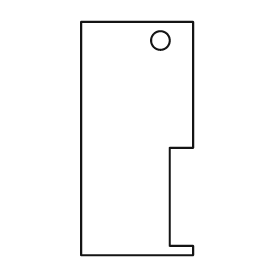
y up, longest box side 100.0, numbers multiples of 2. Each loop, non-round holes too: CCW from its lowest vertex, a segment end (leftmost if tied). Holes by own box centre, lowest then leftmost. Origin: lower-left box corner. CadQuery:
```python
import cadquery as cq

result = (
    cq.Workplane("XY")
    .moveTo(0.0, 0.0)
    .lineTo(48.0, 0.0)
    .lineTo(48.0, 4.0)
    .lineTo(38.0, 4.0)
    .lineTo(38.0, 46.0)
    .lineTo(48.0, 46.0)
    .lineTo(48.0, 100.0)
    .lineTo(0.0, 100.0)
    .close()
    .moveTo(34.0, 92.0)
    .circle(4.0)
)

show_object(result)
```